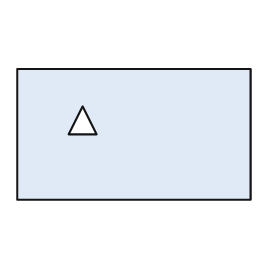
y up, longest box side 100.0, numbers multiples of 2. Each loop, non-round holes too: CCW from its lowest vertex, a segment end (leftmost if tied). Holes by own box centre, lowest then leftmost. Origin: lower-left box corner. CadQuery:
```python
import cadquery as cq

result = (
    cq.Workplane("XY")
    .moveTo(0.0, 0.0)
    .lineTo(100.0, 0.0)
    .lineTo(100.0, 56.0)
    .lineTo(0.0, 56.0)
    .close()
    .moveTo(22.0, 28.0)
    .lineTo(34.0, 28.0)
    .lineTo(28.0, 40.0)
    .close()
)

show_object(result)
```